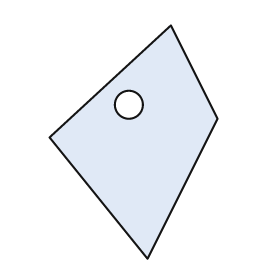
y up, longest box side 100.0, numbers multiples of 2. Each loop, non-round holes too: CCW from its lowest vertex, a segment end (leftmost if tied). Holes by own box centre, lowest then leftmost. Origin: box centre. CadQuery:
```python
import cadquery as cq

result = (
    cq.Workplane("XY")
    .moveTo(6.0, -50.0)
    .lineTo(36.0, 10.0)
    .lineTo(16.0, 50.0)
    .lineTo(-36.0, 2.0)
    .close()
    .moveTo(-2.0, 16.0)
    .circle(6.0)
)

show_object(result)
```